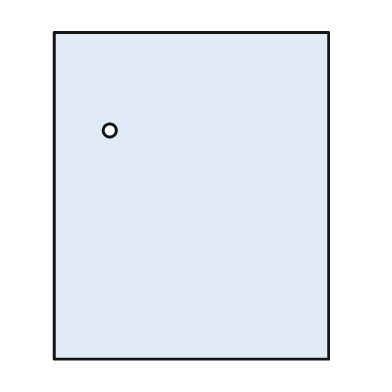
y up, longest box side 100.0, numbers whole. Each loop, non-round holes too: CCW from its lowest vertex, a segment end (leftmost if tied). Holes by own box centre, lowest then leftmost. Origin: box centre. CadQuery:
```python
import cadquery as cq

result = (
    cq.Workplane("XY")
    .moveTo(-42.0, -50.0)
    .lineTo(42.0, -50.0)
    .lineTo(42.0, 50.0)
    .lineTo(-42.0, 50.0)
    .close()
    .moveTo(-25.0, 20.0)
    .circle(2.0)
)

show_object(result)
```